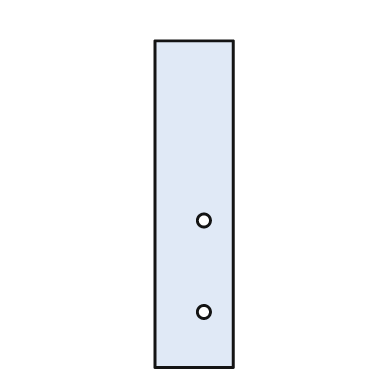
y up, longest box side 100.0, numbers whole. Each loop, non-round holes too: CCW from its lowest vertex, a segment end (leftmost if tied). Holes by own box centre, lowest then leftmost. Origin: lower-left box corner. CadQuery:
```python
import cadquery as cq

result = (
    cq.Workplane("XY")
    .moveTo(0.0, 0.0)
    .lineTo(24.0, 0.0)
    .lineTo(24.0, 100.0)
    .lineTo(0.0, 100.0)
    .close()
    .moveTo(15.0, 17.0)
    .circle(2.0)
    .moveTo(15.0, 45.0)
    .circle(2.0)
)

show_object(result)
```